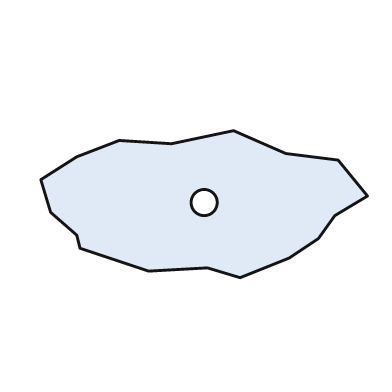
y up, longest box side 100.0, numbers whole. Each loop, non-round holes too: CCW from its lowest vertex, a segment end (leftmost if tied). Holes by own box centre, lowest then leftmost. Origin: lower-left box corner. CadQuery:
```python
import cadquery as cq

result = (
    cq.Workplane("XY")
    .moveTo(61.0, 0.0)
    .lineTo(76.0, 6.0)
    .lineTo(85.0, 12.0)
    .lineTo(90.0, 19.0)
    .lineTo(100.0, 25.0)
    .lineTo(91.0, 36.0)
    .lineTo(75.0, 38.0)
    .lineTo(59.0, 45.0)
    .lineTo(40.0, 41.0)
    .lineTo(24.0, 42.0)
    .lineTo(11.0, 37.0)
    .lineTo(0.0, 30.0)
    .lineTo(3.0, 20.0)
    .lineTo(11.0, 13.0)
    .lineTo(12.0, 9.0)
    .lineTo(33.0, 2.0)
    .lineTo(51.0, 3.0)
    .close()
    .moveTo(50.0, 23.0)
    .circle(4.0)
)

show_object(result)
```